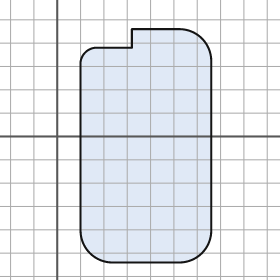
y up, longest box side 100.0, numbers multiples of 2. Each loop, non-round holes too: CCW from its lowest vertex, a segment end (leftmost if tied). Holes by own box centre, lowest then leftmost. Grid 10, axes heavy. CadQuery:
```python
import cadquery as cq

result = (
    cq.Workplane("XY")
    .moveTo(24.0, -54.0)
    .lineTo(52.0, -54.0)
    .threePointArc((62.0, -50.0), (66.0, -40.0))
    .lineTo(66.0, 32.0)
    .threePointArc((62.0, 42.0), (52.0, 46.0))
    .lineTo(32.0, 46.0)
    .lineTo(32.0, 38.0)
    .lineTo(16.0, 38.0)
    .threePointArc((12.0, 36.0), (10.0, 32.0))
    .lineTo(10.0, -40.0)
    .threePointArc((14.0, -50.0), (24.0, -54.0))
    .close()
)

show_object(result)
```